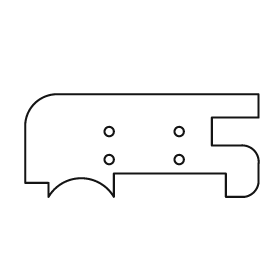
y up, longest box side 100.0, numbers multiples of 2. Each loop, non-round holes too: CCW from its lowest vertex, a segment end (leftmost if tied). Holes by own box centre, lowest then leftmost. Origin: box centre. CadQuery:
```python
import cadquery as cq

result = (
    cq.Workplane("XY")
    .moveTo(-40.0, -22.0)
    .threePointArc((-26.0, -14.0), (-12.0, -22.0))
    .lineTo(-12.0, -12.0)
    .lineTo(36.0, -12.0)
    .lineTo(36.0, -22.0)
    .lineTo(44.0, -22.0)
    .threePointArc((48.0, -20.0), (50.0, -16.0))
    .lineTo(50.0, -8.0)
    .threePointArc((48.0, -2.0), (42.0, 0.0))
    .lineTo(30.0, 0.0)
    .lineTo(30.0, 12.0)
    .lineTo(50.0, 12.0)
    .lineTo(50.0, 22.0)
    .lineTo(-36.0, 22.0)
    .threePointArc((-46.0, 18.0), (-50.0, 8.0))
    .lineTo(-50.0, -16.0)
    .lineTo(-40.0, -16.0)
    .close()
    .moveTo(-14.0, -6.0)
    .circle(2.0)
    .moveTo(16.0, -6.0)
    .circle(2.0)
    .moveTo(-14.0, 6.0)
    .circle(2.0)
    .moveTo(16.0, 6.0)
    .circle(2.0)
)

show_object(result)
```